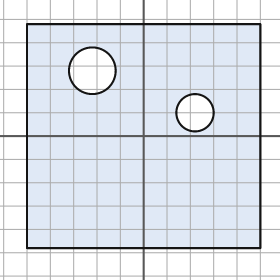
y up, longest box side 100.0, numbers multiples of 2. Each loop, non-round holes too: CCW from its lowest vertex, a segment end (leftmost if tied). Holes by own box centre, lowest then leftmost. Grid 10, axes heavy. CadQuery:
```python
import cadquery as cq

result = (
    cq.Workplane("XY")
    .moveTo(-50.0, -48.0)
    .lineTo(50.0, -48.0)
    .lineTo(50.0, 48.0)
    .lineTo(-50.0, 48.0)
    .close()
    .moveTo(22.0, 10.0)
    .circle(8.0)
    .moveTo(-22.0, 28.0)
    .circle(10.0)
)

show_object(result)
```